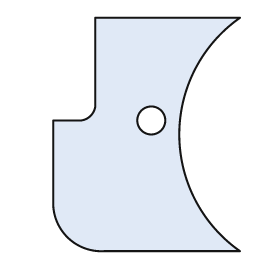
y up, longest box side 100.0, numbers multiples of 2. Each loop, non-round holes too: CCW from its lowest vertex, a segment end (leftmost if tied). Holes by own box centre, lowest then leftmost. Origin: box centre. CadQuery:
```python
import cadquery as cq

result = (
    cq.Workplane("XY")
    .moveTo(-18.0, -50.0)
    .lineTo(40.0, -50.0)
    .threePointArc((14.0, 0.0), (40.0, 50.0))
    .lineTo(-22.0, 50.0)
    .lineTo(-22.0, 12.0)
    .threePointArc((-24.0, 8.0), (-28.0, 6.0))
    .lineTo(-40.0, 6.0)
    .lineTo(-40.0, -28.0)
    .threePointArc((-34.0, -44.0), (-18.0, -50.0))
    .close()
    .moveTo(2.0, 6.0)
    .circle(6.0)
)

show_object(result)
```